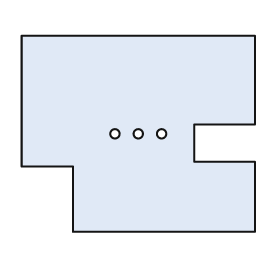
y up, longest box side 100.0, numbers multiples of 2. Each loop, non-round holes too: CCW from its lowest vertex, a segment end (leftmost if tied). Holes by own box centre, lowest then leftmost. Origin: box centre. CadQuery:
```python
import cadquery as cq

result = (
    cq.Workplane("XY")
    .moveTo(-28.0, -42.0)
    .lineTo(50.0, -42.0)
    .lineTo(50.0, -12.0)
    .lineTo(24.0, -12.0)
    .lineTo(24.0, 4.0)
    .lineTo(50.0, 4.0)
    .lineTo(50.0, 42.0)
    .lineTo(-50.0, 42.0)
    .lineTo(-50.0, -14.0)
    .lineTo(-28.0, -14.0)
    .close()
    .moveTo(-10.0, 0.0)
    .circle(2.0)
    .moveTo(0.0, 0.0)
    .circle(2.0)
    .moveTo(10.0, 0.0)
    .circle(2.0)
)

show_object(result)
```